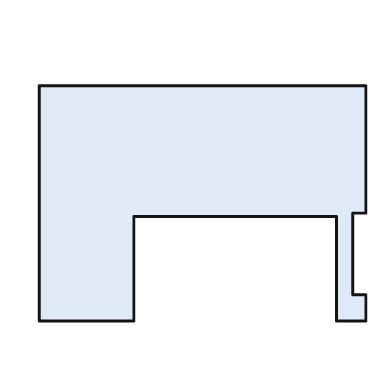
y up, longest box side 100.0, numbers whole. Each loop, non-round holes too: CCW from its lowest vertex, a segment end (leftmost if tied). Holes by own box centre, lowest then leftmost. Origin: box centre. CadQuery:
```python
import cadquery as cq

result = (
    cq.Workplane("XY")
    .moveTo(-50.0, -36.0)
    .lineTo(-21.0, -36.0)
    .lineTo(-21.0, -4.0)
    .lineTo(41.0, -4.0)
    .lineTo(41.0, -36.0)
    .lineTo(50.0, -36.0)
    .lineTo(50.0, -28.0)
    .lineTo(46.0, -28.0)
    .lineTo(46.0, -3.0)
    .lineTo(50.0, -3.0)
    .lineTo(50.0, 36.0)
    .lineTo(-50.0, 36.0)
    .close()
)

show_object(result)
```